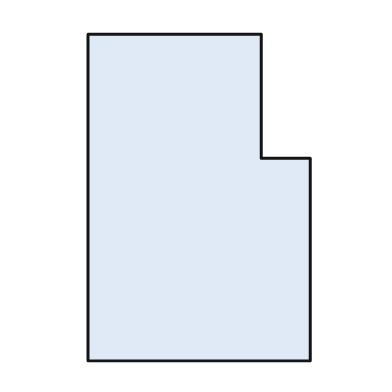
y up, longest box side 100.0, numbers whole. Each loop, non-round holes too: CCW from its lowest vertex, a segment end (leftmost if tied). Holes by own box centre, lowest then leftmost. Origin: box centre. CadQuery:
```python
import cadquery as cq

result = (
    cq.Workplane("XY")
    .moveTo(-34.0, -50.0)
    .lineTo(34.0, -50.0)
    .lineTo(34.0, 12.0)
    .lineTo(19.0, 12.0)
    .lineTo(19.0, 50.0)
    .lineTo(-34.0, 50.0)
    .close()
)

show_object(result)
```